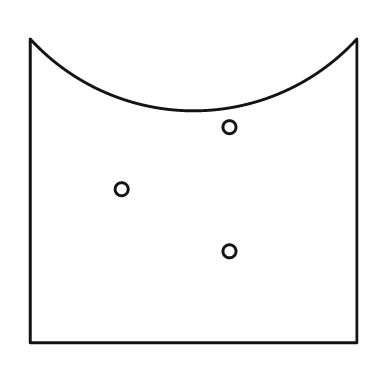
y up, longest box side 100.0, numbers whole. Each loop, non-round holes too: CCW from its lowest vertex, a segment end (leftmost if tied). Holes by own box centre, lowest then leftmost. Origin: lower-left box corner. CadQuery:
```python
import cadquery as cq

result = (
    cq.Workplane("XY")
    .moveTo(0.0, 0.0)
    .lineTo(100.0, 0.0)
    .lineTo(100.0, 93.0)
    .threePointArc((50.0, 71.0), (0.0, 93.0))
    .close()
    .moveTo(61.0, 28.0)
    .circle(2.0)
    .moveTo(28.0, 47.0)
    .circle(2.0)
    .moveTo(61.0, 66.0)
    .circle(2.0)
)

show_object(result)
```